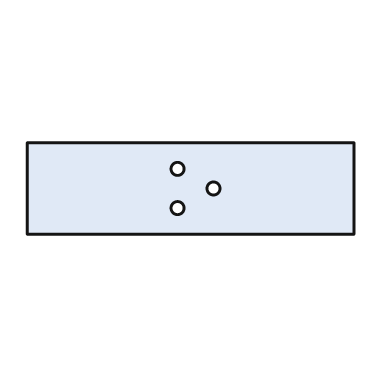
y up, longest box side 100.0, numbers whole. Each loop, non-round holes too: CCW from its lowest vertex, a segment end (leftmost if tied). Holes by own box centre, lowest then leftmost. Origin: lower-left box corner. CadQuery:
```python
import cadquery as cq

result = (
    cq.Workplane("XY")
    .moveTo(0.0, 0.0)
    .lineTo(100.0, 0.0)
    .lineTo(100.0, 28.0)
    .lineTo(0.0, 28.0)
    .close()
    .moveTo(46.0, 8.0)
    .circle(2.0)
    .moveTo(57.0, 14.0)
    .circle(2.0)
    .moveTo(46.0, 20.0)
    .circle(2.0)
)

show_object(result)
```